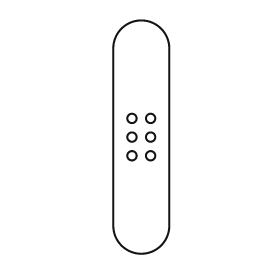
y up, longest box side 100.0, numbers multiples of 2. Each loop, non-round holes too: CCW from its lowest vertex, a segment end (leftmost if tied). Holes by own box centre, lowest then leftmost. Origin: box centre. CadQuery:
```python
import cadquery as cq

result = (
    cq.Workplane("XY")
    .moveTo(-12.0, -38.0)
    .threePointArc((0.0, -50.0), (12.0, -38.0))
    .lineTo(12.0, 38.0)
    .threePointArc((0.0, 50.0), (-12.0, 38.0))
    .close()
    .moveTo(-4.0, -8.0)
    .circle(2.0)
    .moveTo(4.0, -8.0)
    .circle(2.0)
    .moveTo(-4.0, 0.0)
    .circle(2.0)
    .moveTo(4.0, 0.0)
    .circle(2.0)
    .moveTo(-4.0, 8.0)
    .circle(2.0)
    .moveTo(4.0, 8.0)
    .circle(2.0)
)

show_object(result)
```